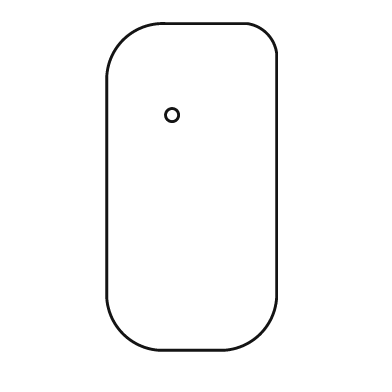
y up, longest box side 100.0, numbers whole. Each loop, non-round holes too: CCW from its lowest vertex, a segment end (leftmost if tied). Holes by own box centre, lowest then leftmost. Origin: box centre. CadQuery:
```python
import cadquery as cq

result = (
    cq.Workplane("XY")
    .moveTo(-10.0, -50.0)
    .lineTo(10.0, -50.0)
    .threePointArc((21.0, -45.0), (26.0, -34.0))
    .lineTo(26.0, 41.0)
    .threePointArc((23.0, 47.0), (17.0, 50.0))
    .lineTo(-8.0, 50.0)
    .threePointArc((-21.0, 45.0), (-26.0, 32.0))
    .lineTo(-26.0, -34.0)
    .threePointArc((-21.0, -45.0), (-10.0, -50.0))
    .close()
    .moveTo(-6.0, 22.0)
    .circle(2.0)
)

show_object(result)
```